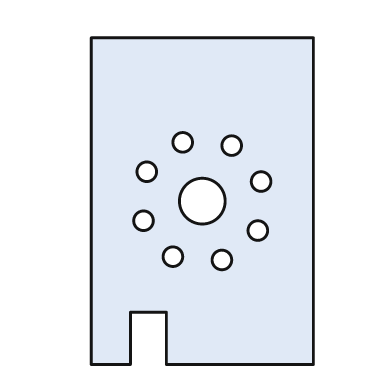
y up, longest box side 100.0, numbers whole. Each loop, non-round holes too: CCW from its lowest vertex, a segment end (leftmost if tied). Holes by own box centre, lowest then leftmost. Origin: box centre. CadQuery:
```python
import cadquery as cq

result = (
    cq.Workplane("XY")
    .moveTo(-34.0, -50.0)
    .lineTo(-22.0, -50.0)
    .lineTo(-22.0, -34.0)
    .lineTo(-11.0, -34.0)
    .lineTo(-11.0, -50.0)
    .lineTo(34.0, -50.0)
    .lineTo(34.0, 50.0)
    .lineTo(-34.0, 50.0)
    .close()
    .moveTo(6.0, -18.0)
    .circle(3.0)
    .moveTo(-9.0, -17.0)
    .circle(3.0)
    .moveTo(17.0, -9.0)
    .circle(3.0)
    .moveTo(-18.0, -6.0)
    .circle(3.0)
    .moveTo(0.0, 0.0)
    .circle(7.0)
    .moveTo(18.0, 6.0)
    .circle(3.0)
    .moveTo(-17.0, 9.0)
    .circle(3.0)
    .moveTo(9.0, 17.0)
    .circle(3.0)
    .moveTo(-6.0, 18.0)
    .circle(3.0)
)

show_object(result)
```